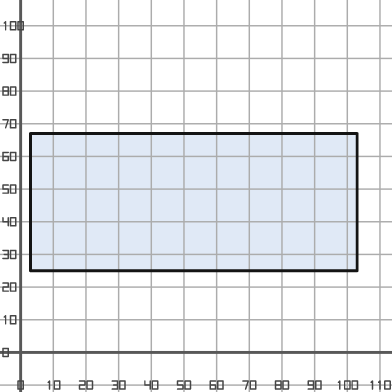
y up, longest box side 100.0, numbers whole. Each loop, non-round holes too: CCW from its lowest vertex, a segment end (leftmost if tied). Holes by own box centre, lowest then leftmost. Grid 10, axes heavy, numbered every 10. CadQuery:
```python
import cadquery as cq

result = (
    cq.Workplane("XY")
    .moveTo(3.0, 25.0)
    .lineTo(103.0, 25.0)
    .lineTo(103.0, 67.0)
    .lineTo(3.0, 67.0)
    .close()
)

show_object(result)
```